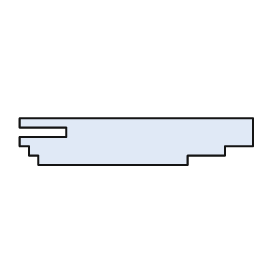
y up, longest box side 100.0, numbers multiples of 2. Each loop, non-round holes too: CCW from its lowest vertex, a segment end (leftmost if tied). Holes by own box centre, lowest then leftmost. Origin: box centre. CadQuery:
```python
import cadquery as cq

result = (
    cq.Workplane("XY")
    .moveTo(-42.0, -10.0)
    .lineTo(22.0, -10.0)
    .lineTo(22.0, -6.0)
    .lineTo(38.0, -6.0)
    .lineTo(38.0, -2.0)
    .lineTo(50.0, -2.0)
    .lineTo(50.0, 10.0)
    .lineTo(-50.0, 10.0)
    .lineTo(-50.0, 6.0)
    .lineTo(-30.0, 6.0)
    .lineTo(-30.0, 2.0)
    .lineTo(-50.0, 2.0)
    .lineTo(-50.0, -2.0)
    .lineTo(-46.0, -2.0)
    .lineTo(-46.0, -6.0)
    .lineTo(-42.0, -6.0)
    .close()
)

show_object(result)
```